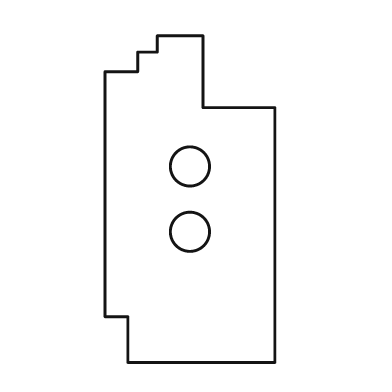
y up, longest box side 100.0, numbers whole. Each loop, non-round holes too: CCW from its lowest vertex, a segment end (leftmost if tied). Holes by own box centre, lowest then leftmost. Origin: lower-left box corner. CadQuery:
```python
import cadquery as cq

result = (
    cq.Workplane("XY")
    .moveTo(7.0, 0.0)
    .lineTo(52.0, 0.0)
    .lineTo(52.0, 78.0)
    .lineTo(30.0, 78.0)
    .lineTo(30.0, 100.0)
    .lineTo(16.0, 100.0)
    .lineTo(16.0, 95.0)
    .lineTo(10.0, 95.0)
    .lineTo(10.0, 89.0)
    .lineTo(0.0, 89.0)
    .lineTo(0.0, 14.0)
    .lineTo(7.0, 14.0)
    .close()
    .moveTo(26.0, 40.0)
    .circle(6.0)
    .moveTo(26.0, 60.0)
    .circle(6.0)
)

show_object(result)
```